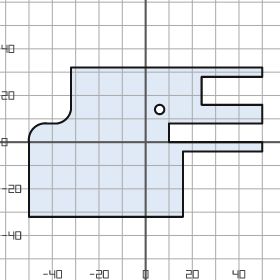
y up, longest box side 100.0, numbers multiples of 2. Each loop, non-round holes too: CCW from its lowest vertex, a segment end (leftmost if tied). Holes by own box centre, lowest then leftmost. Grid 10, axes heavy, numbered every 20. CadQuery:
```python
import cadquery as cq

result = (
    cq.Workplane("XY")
    .moveTo(-50.0, -32.0)
    .lineTo(16.0, -32.0)
    .lineTo(16.0, -4.0)
    .lineTo(50.0, -4.0)
    .lineTo(50.0, 0.0)
    .lineTo(10.0, 0.0)
    .lineTo(10.0, 8.0)
    .lineTo(50.0, 8.0)
    .lineTo(50.0, 16.0)
    .lineTo(24.0, 16.0)
    .lineTo(24.0, 28.0)
    .lineTo(50.0, 28.0)
    .lineTo(50.0, 32.0)
    .lineTo(-32.0, 32.0)
    .lineTo(-32.0, 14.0)
    .threePointArc((-34.0, 10.0), (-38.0, 8.0))
    .lineTo(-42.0, 8.0)
    .threePointArc((-48.0, 6.0), (-50.0, 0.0))
    .close()
    .moveTo(6.0, 14.0)
    .circle(2.0)
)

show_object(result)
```